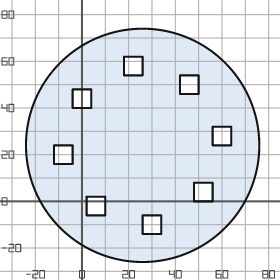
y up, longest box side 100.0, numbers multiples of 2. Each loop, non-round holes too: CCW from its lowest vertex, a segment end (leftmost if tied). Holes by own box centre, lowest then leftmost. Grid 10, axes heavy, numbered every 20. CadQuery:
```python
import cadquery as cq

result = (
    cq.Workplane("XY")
    .moveTo(26.0, 24.0)
    .circle(50.0)
    .moveTo(26.0, -14.0)
    .lineTo(34.0, -14.0)
    .lineTo(34.0, -6.0)
    .lineTo(26.0, -6.0)
    .close()
    .moveTo(2.0, -6.0)
    .lineTo(10.0, -6.0)
    .lineTo(10.0, 2.0)
    .lineTo(2.0, 2.0)
    .close()
    .moveTo(48.0, 0.0)
    .lineTo(56.0, 0.0)
    .lineTo(56.0, 8.0)
    .lineTo(48.0, 8.0)
    .close()
    .moveTo(-12.0, 16.0)
    .lineTo(-4.0, 16.0)
    .lineTo(-4.0, 24.0)
    .lineTo(-12.0, 24.0)
    .close()
    .moveTo(56.0, 24.0)
    .lineTo(64.0, 24.0)
    .lineTo(64.0, 32.0)
    .lineTo(56.0, 32.0)
    .close()
    .moveTo(-4.0, 40.0)
    .lineTo(4.0, 40.0)
    .lineTo(4.0, 48.0)
    .lineTo(-4.0, 48.0)
    .close()
    .moveTo(42.0, 46.0)
    .lineTo(50.0, 46.0)
    .lineTo(50.0, 54.0)
    .lineTo(42.0, 54.0)
    .close()
    .moveTo(18.0, 54.0)
    .lineTo(26.0, 54.0)
    .lineTo(26.0, 62.0)
    .lineTo(18.0, 62.0)
    .close()
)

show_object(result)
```